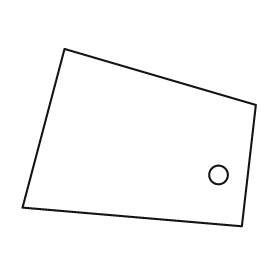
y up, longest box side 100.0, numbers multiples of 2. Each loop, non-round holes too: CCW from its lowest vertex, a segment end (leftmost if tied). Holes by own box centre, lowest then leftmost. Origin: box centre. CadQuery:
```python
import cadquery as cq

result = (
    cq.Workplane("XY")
    .moveTo(44.0, -38.0)
    .lineTo(50.0, 14.0)
    .lineTo(-32.0, 38.0)
    .lineTo(-50.0, -30.0)
    .close()
    .moveTo(34.0, -16.0)
    .circle(4.0)
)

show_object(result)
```